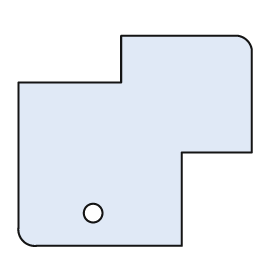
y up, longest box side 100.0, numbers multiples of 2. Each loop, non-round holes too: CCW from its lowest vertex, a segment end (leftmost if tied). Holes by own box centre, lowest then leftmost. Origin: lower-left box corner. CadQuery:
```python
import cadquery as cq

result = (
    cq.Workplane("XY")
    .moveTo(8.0, 0.0)
    .lineTo(70.0, 0.0)
    .lineTo(70.0, 40.0)
    .lineTo(100.0, 40.0)
    .lineTo(100.0, 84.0)
    .threePointArc((98.0, 88.0), (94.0, 90.0))
    .lineTo(44.0, 90.0)
    .lineTo(44.0, 70.0)
    .lineTo(0.0, 70.0)
    .lineTo(0.0, 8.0)
    .threePointArc((2.0, 2.0), (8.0, 0.0))
    .close()
    .moveTo(32.0, 14.0)
    .circle(4.0)
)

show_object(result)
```